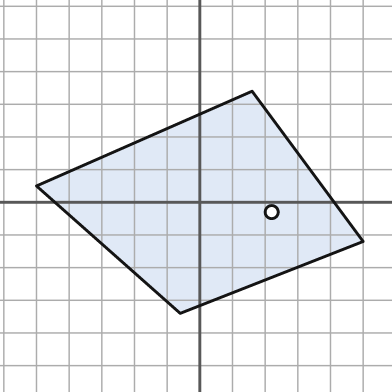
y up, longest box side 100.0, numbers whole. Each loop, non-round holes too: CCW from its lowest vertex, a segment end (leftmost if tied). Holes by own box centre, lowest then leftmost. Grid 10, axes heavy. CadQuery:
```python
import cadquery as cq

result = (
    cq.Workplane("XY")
    .moveTo(-6.0, -34.0)
    .lineTo(50.0, -12.0)
    .lineTo(16.0, 34.0)
    .lineTo(-50.0, 5.0)
    .close()
    .moveTo(22.0, -3.0)
    .circle(2.0)
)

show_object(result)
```